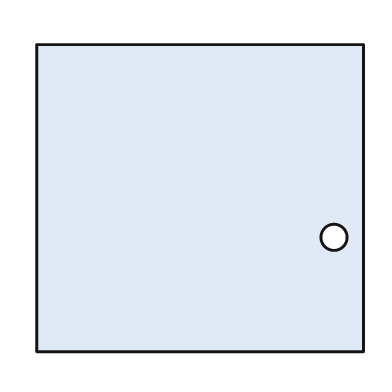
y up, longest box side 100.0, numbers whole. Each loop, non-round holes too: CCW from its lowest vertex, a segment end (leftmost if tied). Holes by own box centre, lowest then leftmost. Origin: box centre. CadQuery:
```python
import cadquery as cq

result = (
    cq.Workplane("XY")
    .moveTo(-50.0, -47.0)
    .lineTo(50.0, -47.0)
    .lineTo(50.0, 47.0)
    .lineTo(-50.0, 47.0)
    .close()
    .moveTo(41.0, -12.0)
    .circle(4.0)
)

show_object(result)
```